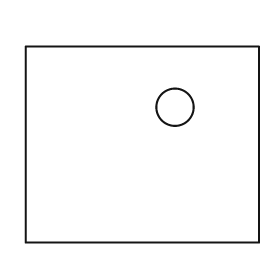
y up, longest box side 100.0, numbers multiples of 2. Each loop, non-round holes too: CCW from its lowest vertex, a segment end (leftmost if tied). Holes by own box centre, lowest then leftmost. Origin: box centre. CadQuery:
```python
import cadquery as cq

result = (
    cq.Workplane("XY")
    .moveTo(-50.0, -42.0)
    .lineTo(50.0, -42.0)
    .lineTo(50.0, 42.0)
    .lineTo(-50.0, 42.0)
    .close()
    .moveTo(14.0, 16.0)
    .circle(8.0)
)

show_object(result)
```